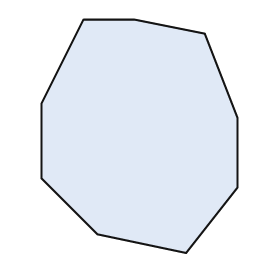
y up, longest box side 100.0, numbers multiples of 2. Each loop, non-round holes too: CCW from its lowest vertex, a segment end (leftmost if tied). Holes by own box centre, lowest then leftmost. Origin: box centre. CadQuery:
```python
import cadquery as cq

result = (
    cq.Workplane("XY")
    .moveTo(20.0, -50.0)
    .lineTo(42.0, -22.0)
    .lineTo(42.0, 8.0)
    .lineTo(28.0, 44.0)
    .lineTo(-2.0, 50.0)
    .lineTo(-24.0, 50.0)
    .lineTo(-42.0, 14.0)
    .lineTo(-42.0, -18.0)
    .lineTo(-18.0, -42.0)
    .close()
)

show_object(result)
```